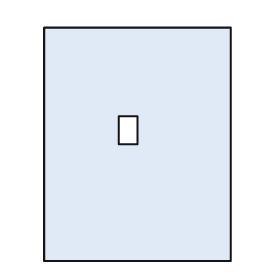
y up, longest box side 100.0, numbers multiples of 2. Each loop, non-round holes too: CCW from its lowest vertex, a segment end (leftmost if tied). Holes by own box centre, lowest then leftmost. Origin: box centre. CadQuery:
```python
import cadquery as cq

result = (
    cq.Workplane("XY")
    .moveTo(-40.0, -50.0)
    .lineTo(40.0, -50.0)
    .lineTo(40.0, 50.0)
    .lineTo(-40.0, 50.0)
    .close()
    .moveTo(-8.0, 0.0)
    .lineTo(0.0, 0.0)
    .lineTo(0.0, 12.0)
    .lineTo(-8.0, 12.0)
    .close()
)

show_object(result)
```